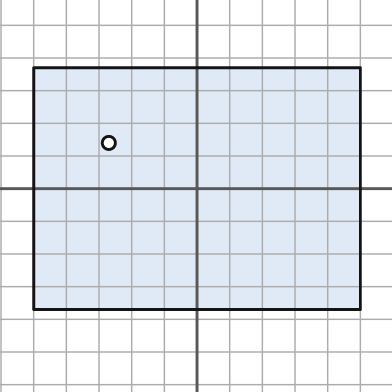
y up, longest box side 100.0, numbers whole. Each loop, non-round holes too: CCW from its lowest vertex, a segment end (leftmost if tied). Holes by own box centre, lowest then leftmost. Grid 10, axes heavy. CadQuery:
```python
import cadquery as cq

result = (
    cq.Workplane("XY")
    .moveTo(-50.0, -37.0)
    .lineTo(50.0, -37.0)
    .lineTo(50.0, 37.0)
    .lineTo(-50.0, 37.0)
    .close()
    .moveTo(-27.0, 14.0)
    .circle(2.0)
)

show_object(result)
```